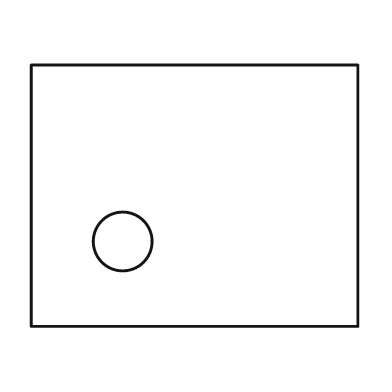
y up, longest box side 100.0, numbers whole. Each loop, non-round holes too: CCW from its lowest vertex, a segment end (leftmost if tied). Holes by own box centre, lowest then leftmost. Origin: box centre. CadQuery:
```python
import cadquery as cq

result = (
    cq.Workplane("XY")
    .moveTo(-50.0, -40.0)
    .lineTo(50.0, -40.0)
    .lineTo(50.0, 40.0)
    .lineTo(-50.0, 40.0)
    .close()
    .moveTo(-22.0, -14.0)
    .circle(9.0)
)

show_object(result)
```